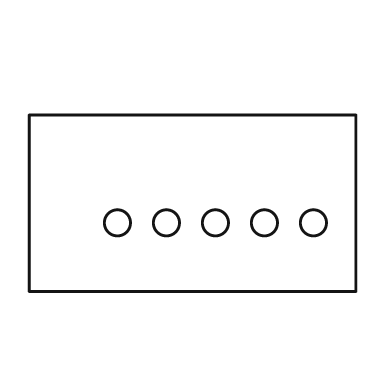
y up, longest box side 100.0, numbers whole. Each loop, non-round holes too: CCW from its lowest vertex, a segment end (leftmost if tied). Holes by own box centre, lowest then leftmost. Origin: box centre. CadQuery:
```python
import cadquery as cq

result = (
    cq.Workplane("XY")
    .moveTo(-50.0, -27.0)
    .lineTo(50.0, -27.0)
    .lineTo(50.0, 27.0)
    .lineTo(-50.0, 27.0)
    .close()
    .moveTo(-23.0, -6.0)
    .circle(4.0)
    .moveTo(-8.0, -6.0)
    .circle(4.0)
    .moveTo(7.0, -6.0)
    .circle(4.0)
    .moveTo(22.0, -6.0)
    .circle(4.0)
    .moveTo(37.0, -6.0)
    .circle(4.0)
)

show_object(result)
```